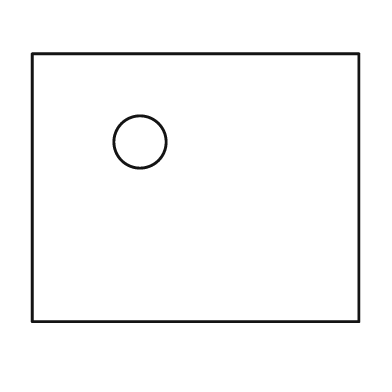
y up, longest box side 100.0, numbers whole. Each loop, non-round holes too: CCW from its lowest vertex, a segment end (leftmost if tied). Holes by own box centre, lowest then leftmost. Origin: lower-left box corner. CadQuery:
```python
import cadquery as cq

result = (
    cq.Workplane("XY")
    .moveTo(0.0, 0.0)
    .lineTo(100.0, 0.0)
    .lineTo(100.0, 82.0)
    .lineTo(0.0, 82.0)
    .close()
    .moveTo(33.0, 55.0)
    .circle(8.0)
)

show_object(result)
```